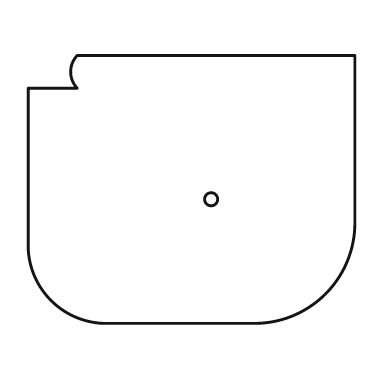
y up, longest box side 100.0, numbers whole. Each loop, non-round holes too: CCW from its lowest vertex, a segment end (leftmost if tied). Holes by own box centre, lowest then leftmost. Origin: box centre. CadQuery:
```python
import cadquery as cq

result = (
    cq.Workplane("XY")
    .moveTo(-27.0, -41.0)
    .lineTo(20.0, -41.0)
    .threePointArc((41.0, -32.0), (50.0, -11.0))
    .lineTo(50.0, 41.0)
    .lineTo(-35.0, 41.0)
    .threePointArc((-37.0, 36.0), (-35.0, 31.0))
    .lineTo(-50.0, 31.0)
    .lineTo(-50.0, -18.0)
    .threePointArc((-43.0, -34.0), (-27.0, -41.0))
    .close()
    .moveTo(6.0, -3.0)
    .circle(2.0)
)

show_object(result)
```